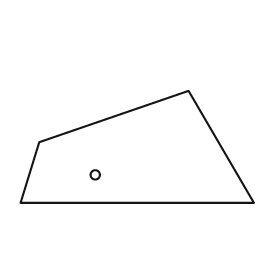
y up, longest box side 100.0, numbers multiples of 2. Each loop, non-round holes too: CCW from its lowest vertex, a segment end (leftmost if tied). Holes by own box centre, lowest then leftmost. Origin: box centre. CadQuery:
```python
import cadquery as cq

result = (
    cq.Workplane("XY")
    .moveTo(-50.0, -24.0)
    .lineTo(50.0, -24.0)
    .lineTo(22.0, 24.0)
    .lineTo(-42.0, 2.0)
    .close()
    .moveTo(-18.0, -12.0)
    .circle(2.0)
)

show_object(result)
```